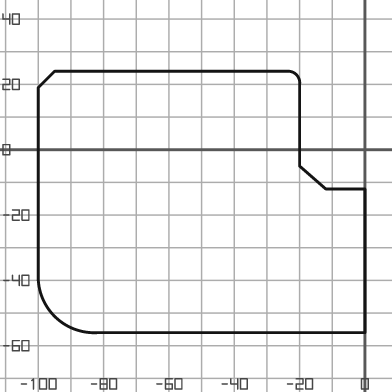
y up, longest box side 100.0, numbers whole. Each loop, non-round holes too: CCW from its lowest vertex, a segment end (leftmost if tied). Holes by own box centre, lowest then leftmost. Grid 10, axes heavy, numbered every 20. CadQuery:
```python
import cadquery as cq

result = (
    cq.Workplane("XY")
    .moveTo(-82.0, -56.0)
    .lineTo(0.0, -56.0)
    .lineTo(0.0, -12.0)
    .lineTo(-12.0, -12.0)
    .lineTo(-20.0, -5.0)
    .lineTo(-20.0, 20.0)
    .threePointArc((-21.0, 23.0), (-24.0, 24.0))
    .lineTo(-95.0, 24.0)
    .lineTo(-100.0, 19.0)
    .lineTo(-100.0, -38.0)
    .threePointArc((-95.0, -51.0), (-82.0, -56.0))
    .close()
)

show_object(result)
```